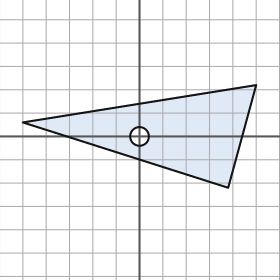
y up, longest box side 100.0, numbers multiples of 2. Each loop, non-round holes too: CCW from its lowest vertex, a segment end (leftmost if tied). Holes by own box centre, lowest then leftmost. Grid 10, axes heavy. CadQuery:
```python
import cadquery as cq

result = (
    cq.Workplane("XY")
    .moveTo(38.0, -22.0)
    .lineTo(50.0, 22.0)
    .lineTo(-50.0, 6.0)
    .close()
    .moveTo(0.0, 0.0)
    .circle(4.0)
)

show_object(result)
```